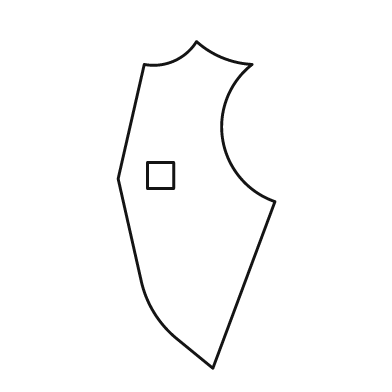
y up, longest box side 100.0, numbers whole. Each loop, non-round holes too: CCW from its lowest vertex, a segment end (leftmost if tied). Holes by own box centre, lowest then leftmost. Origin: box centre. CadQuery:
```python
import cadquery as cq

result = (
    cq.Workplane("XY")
    .moveTo(5.0, -50.0)
    .lineTo(24.0, 1.0)
    .threePointArc((8.0, 20.0), (17.0, 43.0))
    .threePointArc((8.0, 45.0), (0.0, 50.0))
    .threePointArc((-7.0, 44.0), (-16.0, 43.0))
    .lineTo(-24.0, 8.0)
    .lineTo(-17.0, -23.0)
    .threePointArc((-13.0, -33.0), (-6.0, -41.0))
    .close()
    .moveTo(-15.0, 5.0)
    .lineTo(-7.0, 5.0)
    .lineTo(-7.0, 13.0)
    .lineTo(-15.0, 13.0)
    .close()
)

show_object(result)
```